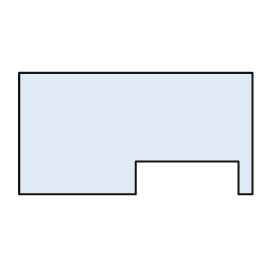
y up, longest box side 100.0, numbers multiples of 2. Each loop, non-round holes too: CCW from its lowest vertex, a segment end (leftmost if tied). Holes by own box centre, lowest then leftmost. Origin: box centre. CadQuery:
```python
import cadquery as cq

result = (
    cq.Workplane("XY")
    .moveTo(-50.0, -26.0)
    .lineTo(0.0, -26.0)
    .lineTo(0.0, -12.0)
    .lineTo(44.0, -12.0)
    .lineTo(44.0, -26.0)
    .lineTo(50.0, -26.0)
    .lineTo(50.0, 26.0)
    .lineTo(-50.0, 26.0)
    .close()
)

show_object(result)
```